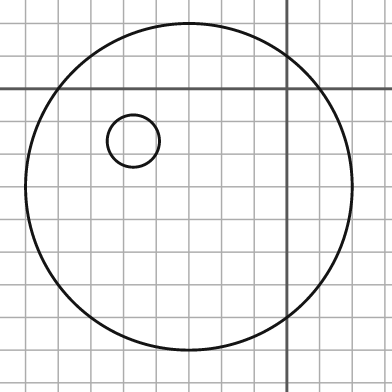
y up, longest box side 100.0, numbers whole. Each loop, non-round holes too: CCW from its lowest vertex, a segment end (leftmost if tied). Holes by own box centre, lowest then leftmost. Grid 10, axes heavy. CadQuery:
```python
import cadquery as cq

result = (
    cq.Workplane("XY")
    .moveTo(-30.0, -30.0)
    .circle(50.0)
    .moveTo(-47.0, -16.0)
    .circle(8.0)
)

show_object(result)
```